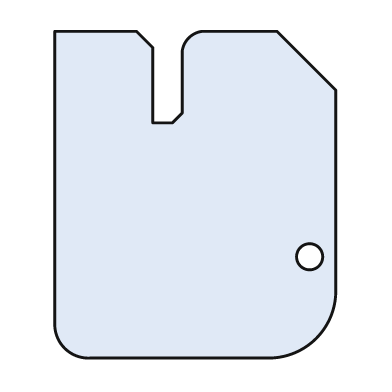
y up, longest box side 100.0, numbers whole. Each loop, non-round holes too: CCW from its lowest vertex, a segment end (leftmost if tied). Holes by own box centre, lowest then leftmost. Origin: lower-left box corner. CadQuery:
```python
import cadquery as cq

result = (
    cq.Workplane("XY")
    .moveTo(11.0, 0.0)
    .lineTo(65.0, 0.0)
    .threePointArc((80.0, 6.0), (86.0, 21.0))
    .lineTo(86.0, 82.0)
    .lineTo(68.0, 100.0)
    .lineTo(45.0, 100.0)
    .threePointArc((41.0, 98.0), (39.0, 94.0))
    .lineTo(39.0, 75.0)
    .lineTo(36.0, 72.0)
    .lineTo(30.0, 72.0)
    .lineTo(30.0, 95.0)
    .lineTo(25.0, 100.0)
    .lineTo(0.0, 100.0)
    .lineTo(0.0, 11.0)
    .threePointArc((3.0, 3.0), (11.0, 0.0))
    .close()
    .moveTo(78.0, 31.0)
    .circle(4.0)
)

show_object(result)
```